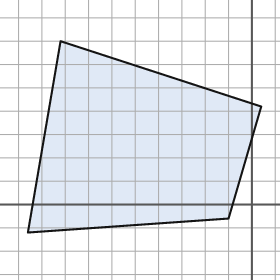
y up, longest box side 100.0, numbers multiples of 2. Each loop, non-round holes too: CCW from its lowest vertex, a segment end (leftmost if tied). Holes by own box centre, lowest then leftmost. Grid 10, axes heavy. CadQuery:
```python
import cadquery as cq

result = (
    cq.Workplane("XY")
    .moveTo(-96.0, -12.0)
    .lineTo(-10.0, -6.0)
    .lineTo(4.0, 42.0)
    .lineTo(-82.0, 70.0)
    .close()
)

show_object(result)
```